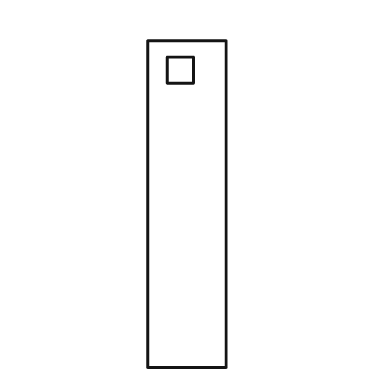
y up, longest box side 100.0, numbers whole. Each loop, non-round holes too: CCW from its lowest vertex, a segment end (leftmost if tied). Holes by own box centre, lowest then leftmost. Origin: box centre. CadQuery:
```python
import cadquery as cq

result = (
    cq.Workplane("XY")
    .moveTo(-12.0, -50.0)
    .lineTo(12.0, -50.0)
    .lineTo(12.0, 50.0)
    .lineTo(-12.0, 50.0)
    .close()
    .moveTo(-6.0, 37.0)
    .lineTo(2.0, 37.0)
    .lineTo(2.0, 45.0)
    .lineTo(-6.0, 45.0)
    .close()
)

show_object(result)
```